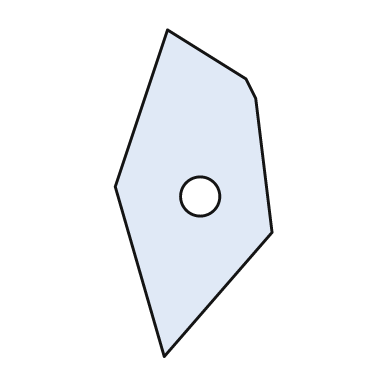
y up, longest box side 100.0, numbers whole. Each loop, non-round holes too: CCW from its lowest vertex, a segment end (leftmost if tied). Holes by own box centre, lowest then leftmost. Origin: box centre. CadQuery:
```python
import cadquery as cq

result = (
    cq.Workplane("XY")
    .moveTo(-9.0, -50.0)
    .lineTo(24.0, -12.0)
    .lineTo(19.0, 29.0)
    .lineTo(16.0, 35.0)
    .lineTo(-8.0, 50.0)
    .lineTo(-24.0, 2.0)
    .close()
    .moveTo(2.0, -1.0)
    .circle(6.0)
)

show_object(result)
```